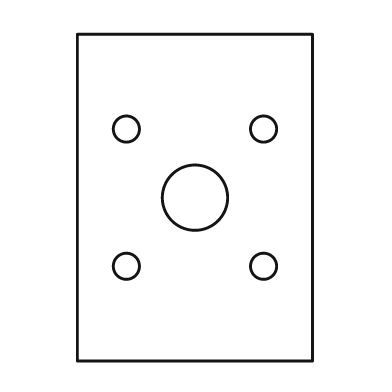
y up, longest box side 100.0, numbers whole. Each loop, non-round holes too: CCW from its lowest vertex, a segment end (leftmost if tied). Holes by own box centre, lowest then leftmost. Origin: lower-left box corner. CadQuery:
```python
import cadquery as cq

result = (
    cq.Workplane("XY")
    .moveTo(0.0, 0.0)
    .lineTo(72.0, 0.0)
    .lineTo(72.0, 100.0)
    .lineTo(0.0, 100.0)
    .close()
    .moveTo(15.0, 29.0)
    .circle(4.0)
    .moveTo(57.0, 29.0)
    .circle(4.0)
    .moveTo(36.0, 50.0)
    .circle(10.0)
    .moveTo(15.0, 71.0)
    .circle(4.0)
    .moveTo(57.0, 71.0)
    .circle(4.0)
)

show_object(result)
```